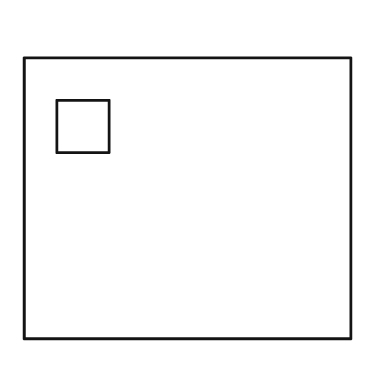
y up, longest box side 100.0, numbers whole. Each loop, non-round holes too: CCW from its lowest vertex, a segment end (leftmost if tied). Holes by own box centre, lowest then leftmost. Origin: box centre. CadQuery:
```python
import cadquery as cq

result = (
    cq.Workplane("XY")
    .moveTo(-50.0, -43.0)
    .lineTo(50.0, -43.0)
    .lineTo(50.0, 43.0)
    .lineTo(-50.0, 43.0)
    .close()
    .moveTo(-40.0, 14.0)
    .lineTo(-24.0, 14.0)
    .lineTo(-24.0, 30.0)
    .lineTo(-40.0, 30.0)
    .close()
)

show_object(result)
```